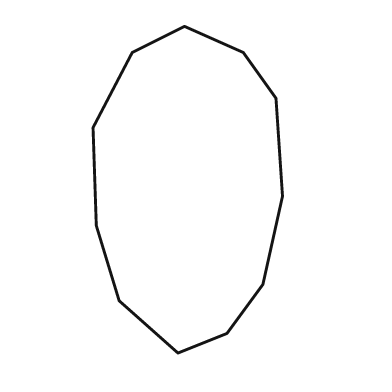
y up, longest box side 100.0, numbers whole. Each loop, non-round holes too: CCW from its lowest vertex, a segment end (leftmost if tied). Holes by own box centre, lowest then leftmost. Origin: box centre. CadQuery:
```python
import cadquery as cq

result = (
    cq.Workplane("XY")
    .moveTo(-3.0, -50.0)
    .lineTo(12.0, -44.0)
    .lineTo(23.0, -29.0)
    .lineTo(29.0, -2.0)
    .lineTo(27.0, 28.0)
    .lineTo(17.0, 42.0)
    .lineTo(-1.0, 50.0)
    .lineTo(-17.0, 42.0)
    .lineTo(-29.0, 19.0)
    .lineTo(-28.0, -11.0)
    .lineTo(-21.0, -34.0)
    .close()
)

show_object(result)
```